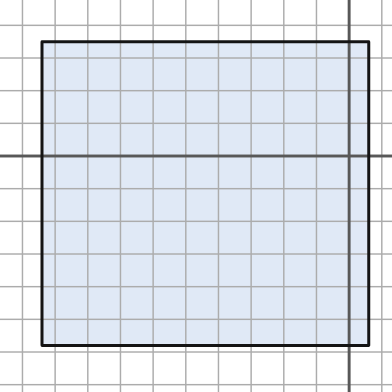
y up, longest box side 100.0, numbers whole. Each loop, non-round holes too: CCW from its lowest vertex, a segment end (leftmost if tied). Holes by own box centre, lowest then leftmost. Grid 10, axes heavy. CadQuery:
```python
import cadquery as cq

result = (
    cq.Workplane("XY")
    .moveTo(-94.0, -58.0)
    .lineTo(6.0, -58.0)
    .lineTo(6.0, 35.0)
    .lineTo(-94.0, 35.0)
    .close()
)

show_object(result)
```